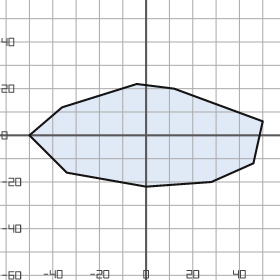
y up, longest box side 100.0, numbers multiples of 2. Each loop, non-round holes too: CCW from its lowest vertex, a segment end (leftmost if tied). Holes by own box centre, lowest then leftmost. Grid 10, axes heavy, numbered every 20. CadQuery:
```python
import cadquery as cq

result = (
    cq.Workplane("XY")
    .moveTo(0.0, -22.0)
    .lineTo(28.0, -20.0)
    .lineTo(46.0, -12.0)
    .lineTo(50.0, 6.0)
    .lineTo(12.0, 20.0)
    .lineTo(-4.0, 22.0)
    .lineTo(-36.0, 12.0)
    .lineTo(-50.0, 0.0)
    .lineTo(-34.0, -16.0)
    .close()
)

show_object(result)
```